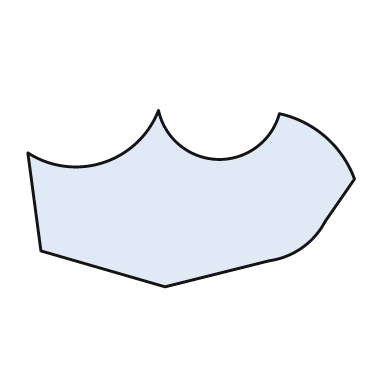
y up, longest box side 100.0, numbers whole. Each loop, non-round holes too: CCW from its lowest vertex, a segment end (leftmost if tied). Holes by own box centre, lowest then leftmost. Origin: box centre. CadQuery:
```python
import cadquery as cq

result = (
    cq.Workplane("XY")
    .moveTo(-8.0, -27.0)
    .lineTo(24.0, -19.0)
    .threePointArc((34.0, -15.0), (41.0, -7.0))
    .lineTo(50.0, 6.0)
    .threePointArc((41.0, 19.0), (27.0, 26.0))
    .threePointArc((8.0, 12.0), (-10.0, 27.0))
    .threePointArc((-27.0, 11.0), (-50.0, 14.0))
    .lineTo(-46.0, -16.0)
    .close()
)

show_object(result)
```